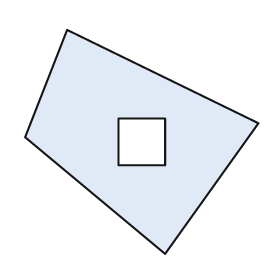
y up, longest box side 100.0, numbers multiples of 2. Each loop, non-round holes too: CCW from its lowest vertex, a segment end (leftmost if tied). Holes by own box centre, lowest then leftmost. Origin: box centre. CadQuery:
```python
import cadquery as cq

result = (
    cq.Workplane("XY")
    .moveTo(10.0, -48.0)
    .lineTo(50.0, 8.0)
    .lineTo(-32.0, 48.0)
    .lineTo(-50.0, 2.0)
    .close()
    .moveTo(-10.0, -10.0)
    .lineTo(10.0, -10.0)
    .lineTo(10.0, 10.0)
    .lineTo(-10.0, 10.0)
    .close()
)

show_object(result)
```